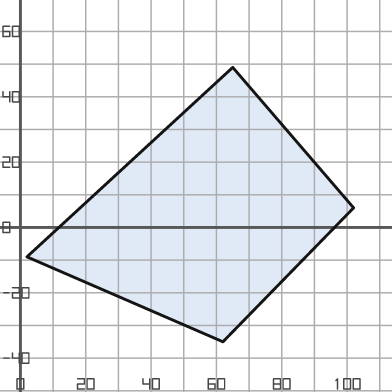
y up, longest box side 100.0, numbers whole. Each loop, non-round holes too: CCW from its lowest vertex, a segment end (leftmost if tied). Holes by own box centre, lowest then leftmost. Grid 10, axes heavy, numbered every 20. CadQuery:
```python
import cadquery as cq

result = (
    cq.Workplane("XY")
    .moveTo(62.0, -35.0)
    .lineTo(102.0, 6.0)
    .lineTo(65.0, 49.0)
    .lineTo(2.0, -9.0)
    .close()
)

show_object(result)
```